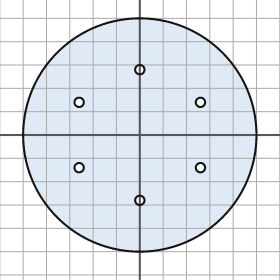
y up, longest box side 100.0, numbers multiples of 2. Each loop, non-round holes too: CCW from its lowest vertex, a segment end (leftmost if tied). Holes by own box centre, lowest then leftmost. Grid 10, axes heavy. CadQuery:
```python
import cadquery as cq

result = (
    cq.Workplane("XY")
    .moveTo(0.0, 0.0)
    .circle(50.0)
    .moveTo(0.0, -28.0)
    .circle(2.0)
    .moveTo(-26.0, -14.0)
    .circle(2.0)
    .moveTo(26.0, -14.0)
    .circle(2.0)
    .moveTo(-26.0, 14.0)
    .circle(2.0)
    .moveTo(26.0, 14.0)
    .circle(2.0)
    .moveTo(0.0, 28.0)
    .circle(2.0)
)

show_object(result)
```